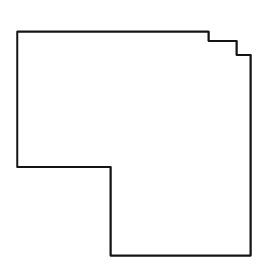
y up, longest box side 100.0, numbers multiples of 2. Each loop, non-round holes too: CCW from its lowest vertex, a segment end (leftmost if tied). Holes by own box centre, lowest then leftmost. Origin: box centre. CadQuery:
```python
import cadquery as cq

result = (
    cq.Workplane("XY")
    .moveTo(-10.0, -48.0)
    .lineTo(50.0, -48.0)
    .lineTo(50.0, 38.0)
    .lineTo(44.0, 38.0)
    .lineTo(44.0, 44.0)
    .lineTo(32.0, 44.0)
    .lineTo(32.0, 48.0)
    .lineTo(-50.0, 48.0)
    .lineTo(-50.0, -10.0)
    .lineTo(-10.0, -10.0)
    .close()
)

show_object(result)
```